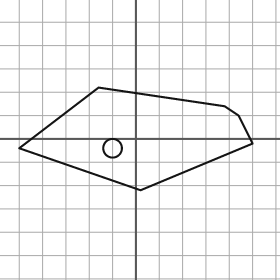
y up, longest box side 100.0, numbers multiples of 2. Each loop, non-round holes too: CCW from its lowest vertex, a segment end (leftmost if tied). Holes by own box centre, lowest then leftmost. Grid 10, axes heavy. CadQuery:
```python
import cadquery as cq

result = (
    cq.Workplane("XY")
    .moveTo(2.0, -22.0)
    .lineTo(50.0, -2.0)
    .lineTo(44.0, 10.0)
    .lineTo(38.0, 14.0)
    .lineTo(-16.0, 22.0)
    .lineTo(-50.0, -4.0)
    .close()
    .moveTo(-10.0, -4.0)
    .circle(4.0)
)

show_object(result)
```